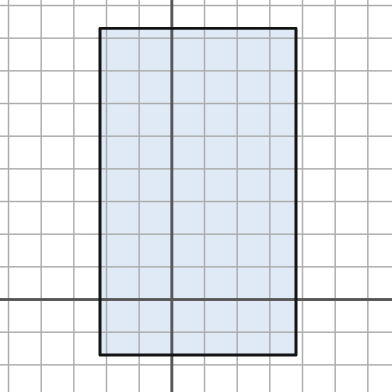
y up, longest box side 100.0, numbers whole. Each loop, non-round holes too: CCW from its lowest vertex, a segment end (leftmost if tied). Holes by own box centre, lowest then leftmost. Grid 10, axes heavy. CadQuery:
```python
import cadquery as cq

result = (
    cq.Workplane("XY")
    .moveTo(-22.0, -17.0)
    .lineTo(38.0, -17.0)
    .lineTo(38.0, 83.0)
    .lineTo(-22.0, 83.0)
    .close()
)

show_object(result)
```